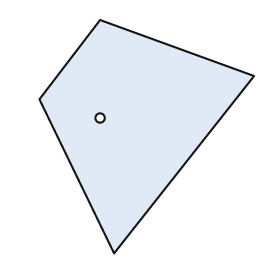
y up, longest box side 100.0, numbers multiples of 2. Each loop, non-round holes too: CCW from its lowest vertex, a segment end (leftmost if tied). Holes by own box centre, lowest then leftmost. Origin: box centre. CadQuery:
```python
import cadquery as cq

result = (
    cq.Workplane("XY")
    .moveTo(-14.0, -50.0)
    .lineTo(46.0, 26.0)
    .lineTo(-20.0, 50.0)
    .lineTo(-46.0, 16.0)
    .close()
    .moveTo(-20.0, 8.0)
    .circle(2.0)
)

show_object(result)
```